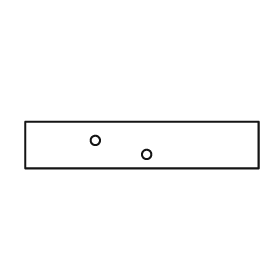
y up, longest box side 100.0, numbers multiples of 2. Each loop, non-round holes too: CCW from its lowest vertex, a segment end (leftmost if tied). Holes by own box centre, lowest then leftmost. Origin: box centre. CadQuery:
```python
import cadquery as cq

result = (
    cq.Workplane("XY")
    .moveTo(-50.0, -10.0)
    .lineTo(50.0, -10.0)
    .lineTo(50.0, 10.0)
    .lineTo(-50.0, 10.0)
    .close()
    .moveTo(2.0, -4.0)
    .circle(2.0)
    .moveTo(-20.0, 2.0)
    .circle(2.0)
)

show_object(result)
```